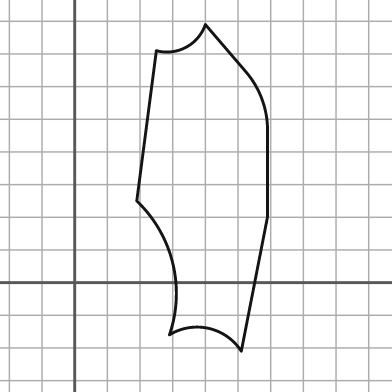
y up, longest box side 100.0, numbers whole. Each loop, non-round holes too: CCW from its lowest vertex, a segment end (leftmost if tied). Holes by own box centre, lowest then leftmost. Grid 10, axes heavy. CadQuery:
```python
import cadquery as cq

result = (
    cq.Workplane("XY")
    .moveTo(51.0, -21.0)
    .lineTo(59.0, 20.0)
    .lineTo(59.0, 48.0)
    .threePointArc((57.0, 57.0), (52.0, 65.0))
    .lineTo(40.0, 79.0)
    .threePointArc((34.0, 72.0), (25.0, 71.0))
    .lineTo(19.0, 25.0)
    .threePointArc((30.0, 6.0), (29.0, -16.0))
    .threePointArc((41.0, -14.0), (51.0, -21.0))
    .close()
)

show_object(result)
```